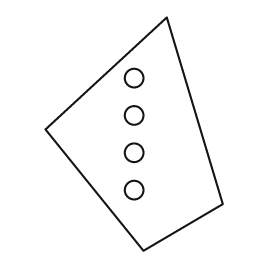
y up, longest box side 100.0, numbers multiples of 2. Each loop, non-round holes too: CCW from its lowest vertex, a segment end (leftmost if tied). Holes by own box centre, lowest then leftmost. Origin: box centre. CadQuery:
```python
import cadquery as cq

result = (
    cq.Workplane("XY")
    .moveTo(4.0, -50.0)
    .lineTo(38.0, -30.0)
    .lineTo(14.0, 50.0)
    .lineTo(-38.0, 2.0)
    .close()
    .moveTo(0.0, -24.0)
    .circle(4.0)
    .moveTo(0.0, -8.0)
    .circle(4.0)
    .moveTo(0.0, 8.0)
    .circle(4.0)
    .moveTo(0.0, 24.0)
    .circle(4.0)
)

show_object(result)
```